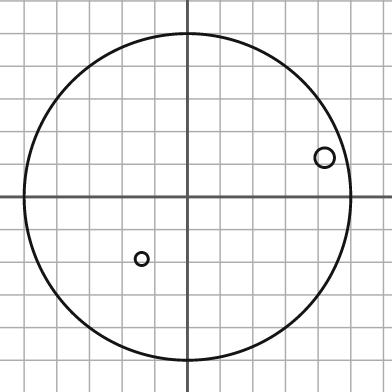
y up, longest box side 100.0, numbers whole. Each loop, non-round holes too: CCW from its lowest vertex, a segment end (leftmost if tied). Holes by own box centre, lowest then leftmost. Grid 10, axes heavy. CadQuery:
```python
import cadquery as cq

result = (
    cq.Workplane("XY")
    .moveTo(0.0, 0.0)
    .circle(50.0)
    .moveTo(-14.0, -19.0)
    .circle(2.0)
    .moveTo(42.0, 12.0)
    .circle(3.0)
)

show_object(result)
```